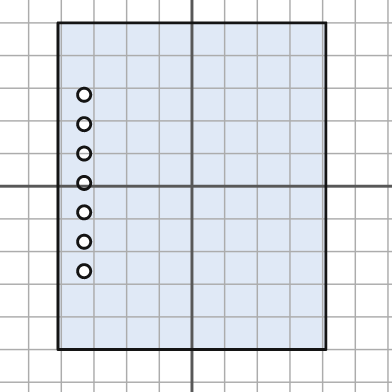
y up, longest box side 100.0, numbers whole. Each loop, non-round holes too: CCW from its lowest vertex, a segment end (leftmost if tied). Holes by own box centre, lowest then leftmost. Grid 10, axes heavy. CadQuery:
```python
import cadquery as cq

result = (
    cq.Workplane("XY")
    .moveTo(-41.0, -50.0)
    .lineTo(41.0, -50.0)
    .lineTo(41.0, 50.0)
    .lineTo(-41.0, 50.0)
    .close()
    .moveTo(-33.0, -26.0)
    .circle(2.0)
    .moveTo(-33.0, -17.0)
    .circle(2.0)
    .moveTo(-33.0, -8.0)
    .circle(2.0)
    .moveTo(-33.0, 1.0)
    .circle(2.0)
    .moveTo(-33.0, 10.0)
    .circle(2.0)
    .moveTo(-33.0, 19.0)
    .circle(2.0)
    .moveTo(-33.0, 28.0)
    .circle(2.0)
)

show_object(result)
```